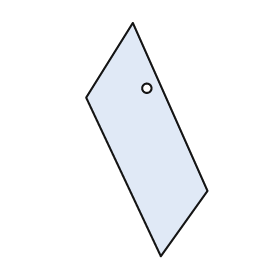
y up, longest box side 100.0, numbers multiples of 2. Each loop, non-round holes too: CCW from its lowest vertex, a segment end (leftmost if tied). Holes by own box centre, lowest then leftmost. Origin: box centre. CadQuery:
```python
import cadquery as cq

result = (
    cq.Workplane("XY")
    .moveTo(6.0, -50.0)
    .lineTo(26.0, -22.0)
    .lineTo(-6.0, 50.0)
    .lineTo(-26.0, 18.0)
    .close()
    .moveTo(0.0, 22.0)
    .circle(2.0)
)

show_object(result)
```